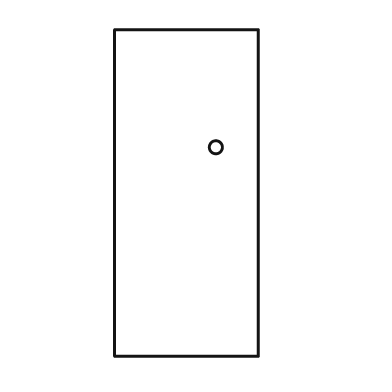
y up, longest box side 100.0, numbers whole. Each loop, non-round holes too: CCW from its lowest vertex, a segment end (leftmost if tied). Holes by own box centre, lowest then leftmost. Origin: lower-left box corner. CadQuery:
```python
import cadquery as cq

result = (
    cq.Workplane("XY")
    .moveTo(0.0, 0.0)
    .lineTo(44.0, 0.0)
    .lineTo(44.0, 100.0)
    .lineTo(0.0, 100.0)
    .close()
    .moveTo(31.0, 64.0)
    .circle(2.0)
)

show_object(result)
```